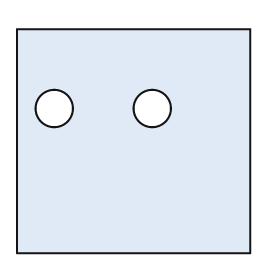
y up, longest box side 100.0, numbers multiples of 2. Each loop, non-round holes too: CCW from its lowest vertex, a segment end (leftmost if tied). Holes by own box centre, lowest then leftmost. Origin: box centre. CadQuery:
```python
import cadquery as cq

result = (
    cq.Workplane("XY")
    .moveTo(-50.0, -48.0)
    .lineTo(50.0, -48.0)
    .lineTo(50.0, 48.0)
    .lineTo(-50.0, 48.0)
    .close()
    .moveTo(-34.0, 14.0)
    .circle(8.0)
    .moveTo(8.0, 14.0)
    .circle(8.0)
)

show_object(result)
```